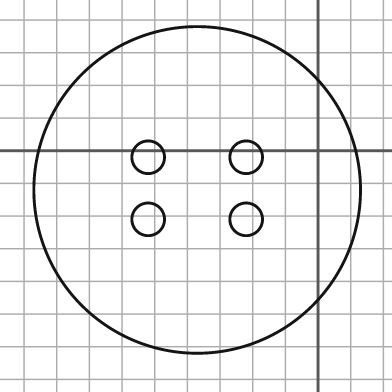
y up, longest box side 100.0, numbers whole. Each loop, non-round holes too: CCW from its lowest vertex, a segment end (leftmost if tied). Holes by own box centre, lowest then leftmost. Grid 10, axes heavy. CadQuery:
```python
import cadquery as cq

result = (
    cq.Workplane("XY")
    .moveTo(-37.0, -12.0)
    .circle(50.0)
    .moveTo(-52.0, -21.0)
    .circle(5.0)
    .moveTo(-22.0, -21.0)
    .circle(5.0)
    .moveTo(-52.0, -2.0)
    .circle(5.0)
    .moveTo(-22.0, -2.0)
    .circle(5.0)
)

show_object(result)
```